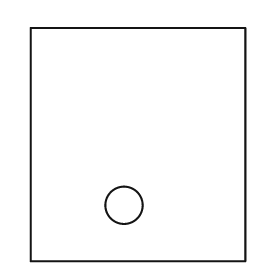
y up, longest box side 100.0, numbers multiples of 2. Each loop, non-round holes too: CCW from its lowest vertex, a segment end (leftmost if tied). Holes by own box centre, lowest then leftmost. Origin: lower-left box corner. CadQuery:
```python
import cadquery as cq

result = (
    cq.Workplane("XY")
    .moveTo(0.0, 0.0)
    .lineTo(92.0, 0.0)
    .lineTo(92.0, 100.0)
    .lineTo(0.0, 100.0)
    .close()
    .moveTo(40.0, 24.0)
    .circle(8.0)
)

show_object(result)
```